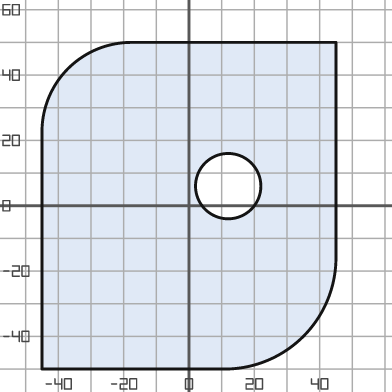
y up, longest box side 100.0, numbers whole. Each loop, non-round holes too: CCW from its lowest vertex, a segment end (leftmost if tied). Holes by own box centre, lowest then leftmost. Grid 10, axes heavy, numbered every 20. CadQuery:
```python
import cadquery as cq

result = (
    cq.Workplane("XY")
    .moveTo(-45.0, -50.0)
    .lineTo(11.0, -50.0)
    .threePointArc((35.0, -40.0), (45.0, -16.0))
    .lineTo(45.0, 50.0)
    .lineTo(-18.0, 50.0)
    .threePointArc((-37.0, 42.0), (-45.0, 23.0))
    .close()
    .moveTo(12.0, 6.0)
    .circle(10.0)
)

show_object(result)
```